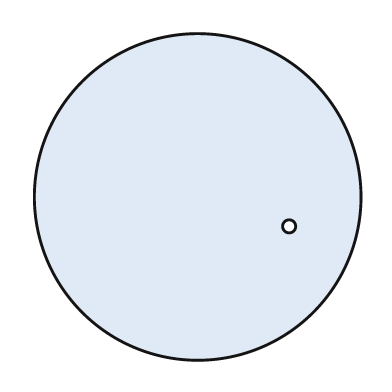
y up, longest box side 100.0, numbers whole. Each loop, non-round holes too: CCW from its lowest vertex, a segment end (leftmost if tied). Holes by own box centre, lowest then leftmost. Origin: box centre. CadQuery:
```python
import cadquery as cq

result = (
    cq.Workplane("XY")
    .moveTo(0.0, 0.0)
    .circle(50.0)
    .moveTo(28.0, -9.0)
    .circle(2.0)
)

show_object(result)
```